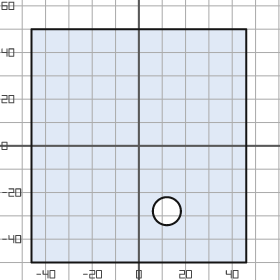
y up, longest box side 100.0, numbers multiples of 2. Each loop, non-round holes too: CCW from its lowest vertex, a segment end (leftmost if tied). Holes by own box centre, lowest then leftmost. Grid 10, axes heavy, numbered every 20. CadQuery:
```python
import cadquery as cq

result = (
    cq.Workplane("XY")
    .moveTo(-46.0, -50.0)
    .lineTo(46.0, -50.0)
    .lineTo(46.0, 50.0)
    .lineTo(-46.0, 50.0)
    .close()
    .moveTo(12.0, -28.0)
    .circle(6.0)
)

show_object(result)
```